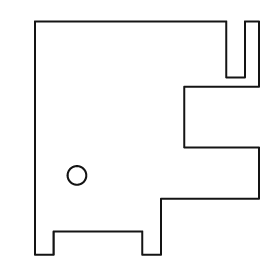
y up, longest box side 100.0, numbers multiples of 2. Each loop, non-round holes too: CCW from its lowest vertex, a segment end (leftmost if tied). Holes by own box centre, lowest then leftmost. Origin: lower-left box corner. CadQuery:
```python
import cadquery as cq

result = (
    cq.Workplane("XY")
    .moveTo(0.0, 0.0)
    .lineTo(8.0, 0.0)
    .lineTo(8.0, 10.0)
    .lineTo(46.0, 10.0)
    .lineTo(46.0, 0.0)
    .lineTo(54.0, 0.0)
    .lineTo(54.0, 24.0)
    .lineTo(96.0, 24.0)
    .lineTo(96.0, 46.0)
    .lineTo(64.0, 46.0)
    .lineTo(64.0, 72.0)
    .lineTo(96.0, 72.0)
    .lineTo(96.0, 100.0)
    .lineTo(90.0, 100.0)
    .lineTo(90.0, 76.0)
    .lineTo(82.0, 76.0)
    .lineTo(82.0, 100.0)
    .lineTo(0.0, 100.0)
    .close()
    .moveTo(18.0, 34.0)
    .circle(4.0)
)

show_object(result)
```